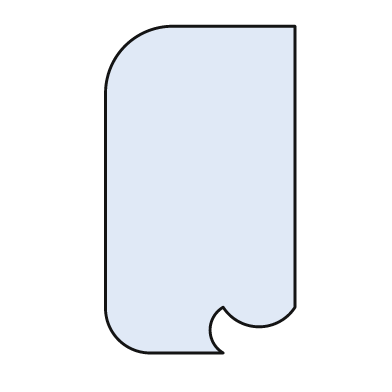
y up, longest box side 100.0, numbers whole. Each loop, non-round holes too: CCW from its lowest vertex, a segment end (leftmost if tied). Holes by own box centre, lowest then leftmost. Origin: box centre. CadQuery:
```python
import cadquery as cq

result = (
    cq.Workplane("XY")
    .moveTo(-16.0, -50.0)
    .lineTo(7.0, -50.0)
    .threePointArc((3.0, -43.0), (7.0, -36.0))
    .threePointArc((18.0, -42.0), (29.0, -36.0))
    .lineTo(29.0, 50.0)
    .lineTo(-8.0, 50.0)
    .threePointArc((-23.0, 44.0), (-29.0, 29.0))
    .lineTo(-29.0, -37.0)
    .threePointArc((-25.0, -46.0), (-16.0, -50.0))
    .close()
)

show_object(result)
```